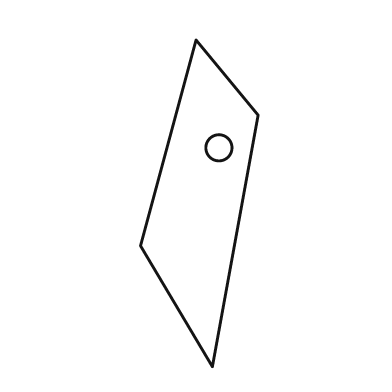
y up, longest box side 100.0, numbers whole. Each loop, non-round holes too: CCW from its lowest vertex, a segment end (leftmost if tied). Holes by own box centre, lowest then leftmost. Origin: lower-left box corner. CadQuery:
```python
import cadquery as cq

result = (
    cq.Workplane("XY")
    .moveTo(22.0, 0.0)
    .lineTo(36.0, 77.0)
    .lineTo(17.0, 100.0)
    .lineTo(0.0, 37.0)
    .close()
    .moveTo(24.0, 67.0)
    .circle(4.0)
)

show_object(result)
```